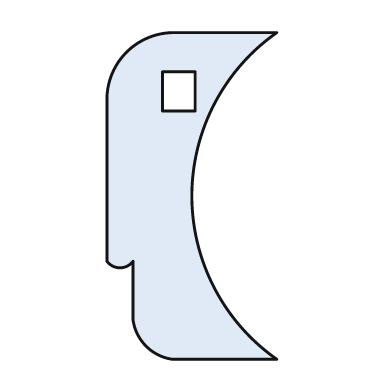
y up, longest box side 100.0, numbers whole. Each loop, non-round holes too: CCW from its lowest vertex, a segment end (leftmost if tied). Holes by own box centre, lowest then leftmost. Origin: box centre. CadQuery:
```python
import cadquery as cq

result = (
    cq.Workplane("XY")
    .moveTo(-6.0, -50.0)
    .lineTo(26.0, -50.0)
    .threePointArc((0.0, 0.0), (26.0, 50.0))
    .lineTo(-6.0, 50.0)
    .threePointArc((-20.0, 44.0), (-26.0, 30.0))
    .lineTo(-26.0, -20.0)
    .threePointArc((-22.0, -22.0), (-18.0, -20.0))
    .lineTo(-18.0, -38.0)
    .threePointArc((-14.0, -46.0), (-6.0, -50.0))
    .close()
    .moveTo(-9.0, 26.0)
    .lineTo(1.0, 26.0)
    .lineTo(1.0, 38.0)
    .lineTo(-9.0, 38.0)
    .close()
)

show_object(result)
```